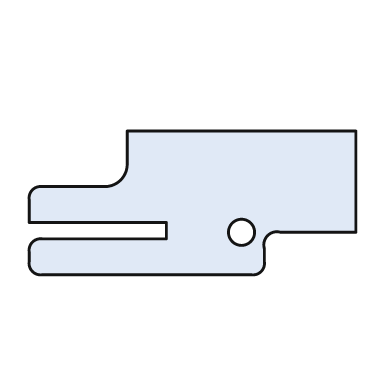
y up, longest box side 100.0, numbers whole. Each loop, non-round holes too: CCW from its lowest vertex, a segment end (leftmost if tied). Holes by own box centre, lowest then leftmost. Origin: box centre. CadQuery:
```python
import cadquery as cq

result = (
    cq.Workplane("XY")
    .moveTo(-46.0, -22.0)
    .lineTo(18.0, -22.0)
    .threePointArc((21.0, -21.0), (22.0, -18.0))
    .lineTo(22.0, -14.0)
    .threePointArc((23.0, -10.0), (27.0, -9.0))
    .lineTo(50.0, -9.0)
    .lineTo(50.0, 22.0)
    .lineTo(-20.0, 22.0)
    .lineTo(-20.0, 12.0)
    .threePointArc((-22.0, 7.0), (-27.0, 5.0))
    .lineTo(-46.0, 5.0)
    .threePointArc((-49.0, 4.0), (-50.0, 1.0))
    .lineTo(-50.0, -6.0)
    .lineTo(-8.0, -6.0)
    .lineTo(-8.0, -11.0)
    .lineTo(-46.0, -11.0)
    .threePointArc((-49.0, -12.0), (-50.0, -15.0))
    .lineTo(-50.0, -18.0)
    .threePointArc((-49.0, -21.0), (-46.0, -22.0))
    .close()
    .moveTo(15.0, -9.0)
    .circle(4.0)
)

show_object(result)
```